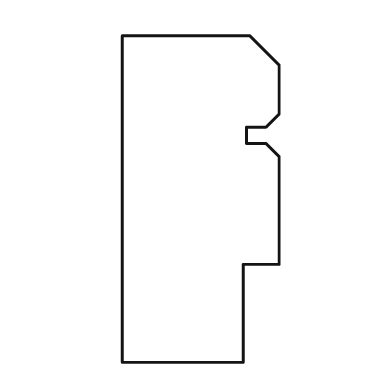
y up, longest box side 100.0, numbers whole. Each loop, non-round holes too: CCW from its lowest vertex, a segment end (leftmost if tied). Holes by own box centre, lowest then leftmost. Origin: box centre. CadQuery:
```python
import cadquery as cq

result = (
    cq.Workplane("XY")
    .moveTo(-24.0, -50.0)
    .lineTo(13.0, -50.0)
    .lineTo(13.0, -20.0)
    .lineTo(24.0, -20.0)
    .lineTo(24.0, 13.0)
    .lineTo(20.0, 17.0)
    .lineTo(14.0, 17.0)
    .lineTo(14.0, 22.0)
    .lineTo(20.0, 22.0)
    .lineTo(24.0, 26.0)
    .lineTo(24.0, 41.0)
    .lineTo(15.0, 50.0)
    .lineTo(-24.0, 50.0)
    .close()
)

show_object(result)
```